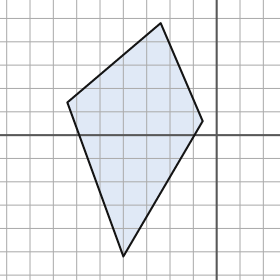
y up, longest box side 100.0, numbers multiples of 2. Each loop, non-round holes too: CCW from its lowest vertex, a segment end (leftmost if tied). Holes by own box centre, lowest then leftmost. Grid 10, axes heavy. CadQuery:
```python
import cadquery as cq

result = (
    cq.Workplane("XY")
    .moveTo(-40.0, -52.0)
    .lineTo(-6.0, 6.0)
    .lineTo(-24.0, 48.0)
    .lineTo(-64.0, 14.0)
    .close()
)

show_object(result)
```